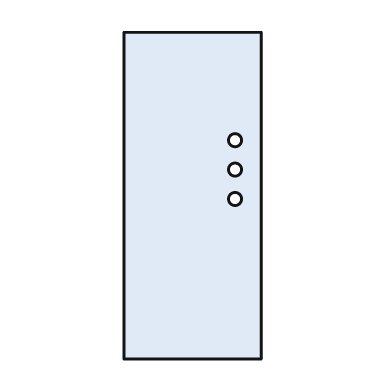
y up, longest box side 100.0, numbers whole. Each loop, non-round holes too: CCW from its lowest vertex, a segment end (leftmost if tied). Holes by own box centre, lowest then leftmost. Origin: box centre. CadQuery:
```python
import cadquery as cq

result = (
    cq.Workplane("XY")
    .moveTo(-21.0, -50.0)
    .lineTo(21.0, -50.0)
    .lineTo(21.0, 50.0)
    .lineTo(-21.0, 50.0)
    .close()
    .moveTo(13.0, -1.0)
    .circle(2.0)
    .moveTo(13.0, 8.0)
    .circle(2.0)
    .moveTo(13.0, 17.0)
    .circle(2.0)
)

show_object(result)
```